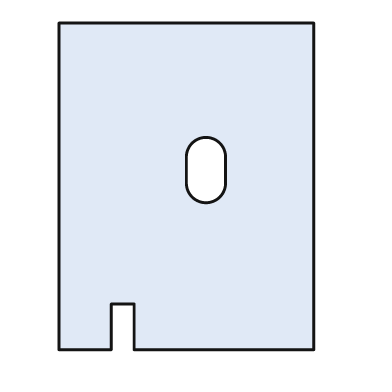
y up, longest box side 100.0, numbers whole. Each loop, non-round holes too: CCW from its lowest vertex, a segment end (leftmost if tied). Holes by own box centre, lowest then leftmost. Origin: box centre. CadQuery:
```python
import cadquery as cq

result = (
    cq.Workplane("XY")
    .moveTo(-39.0, -50.0)
    .lineTo(-23.0, -50.0)
    .lineTo(-23.0, -36.0)
    .lineTo(-16.0, -36.0)
    .lineTo(-16.0, -50.0)
    .lineTo(39.0, -50.0)
    .lineTo(39.0, 50.0)
    .lineTo(-39.0, 50.0)
    .close()
    .moveTo(0.0, 1.0)
    .threePointArc((6.0, -5.0), (12.0, 1.0))
    .lineTo(12.0, 9.0)
    .threePointArc((6.0, 15.0), (0.0, 9.0))
    .close()
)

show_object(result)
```